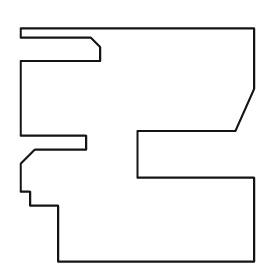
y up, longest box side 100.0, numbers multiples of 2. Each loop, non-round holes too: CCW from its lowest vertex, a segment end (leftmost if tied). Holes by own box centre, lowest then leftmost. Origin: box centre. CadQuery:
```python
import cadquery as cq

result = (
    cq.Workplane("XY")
    .moveTo(-34.0, -50.0)
    .lineTo(50.0, -50.0)
    .lineTo(50.0, -14.0)
    .lineTo(0.0, -14.0)
    .lineTo(0.0, 6.0)
    .lineTo(42.0, 6.0)
    .lineTo(50.0, 24.0)
    .lineTo(50.0, 50.0)
    .lineTo(-50.0, 50.0)
    .lineTo(-50.0, 46.0)
    .lineTo(-20.0, 46.0)
    .lineTo(-16.0, 42.0)
    .lineTo(-16.0, 36.0)
    .lineTo(-50.0, 36.0)
    .lineTo(-50.0, 4.0)
    .lineTo(-22.0, 4.0)
    .lineTo(-22.0, -2.0)
    .lineTo(-44.0, -2.0)
    .lineTo(-50.0, -8.0)
    .lineTo(-50.0, -20.0)
    .lineTo(-46.0, -20.0)
    .lineTo(-46.0, -26.0)
    .lineTo(-34.0, -26.0)
    .close()
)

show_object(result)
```